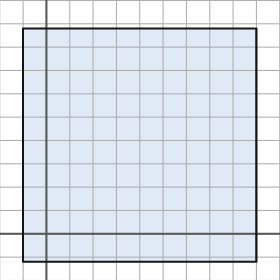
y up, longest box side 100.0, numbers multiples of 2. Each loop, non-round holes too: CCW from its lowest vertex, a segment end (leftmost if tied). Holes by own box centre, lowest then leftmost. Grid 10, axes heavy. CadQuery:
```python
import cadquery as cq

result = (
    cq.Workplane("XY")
    .moveTo(-10.0, -12.0)
    .lineTo(90.0, -12.0)
    .lineTo(90.0, 88.0)
    .lineTo(-10.0, 88.0)
    .close()
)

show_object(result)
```